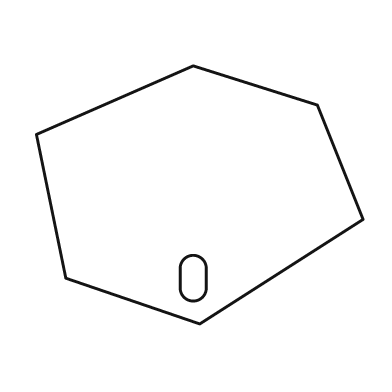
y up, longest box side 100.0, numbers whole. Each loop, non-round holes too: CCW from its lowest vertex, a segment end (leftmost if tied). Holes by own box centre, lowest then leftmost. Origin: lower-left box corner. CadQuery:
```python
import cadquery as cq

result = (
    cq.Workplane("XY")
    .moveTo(50.0, 0.0)
    .lineTo(100.0, 32.0)
    .lineTo(86.0, 67.0)
    .lineTo(48.0, 79.0)
    .lineTo(0.0, 58.0)
    .lineTo(9.0, 14.0)
    .close()
    .moveTo(44.0, 11.0)
    .threePointArc((48.0, 7.0), (52.0, 11.0))
    .lineTo(52.0, 17.0)
    .threePointArc((48.0, 21.0), (44.0, 17.0))
    .close()
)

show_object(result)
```